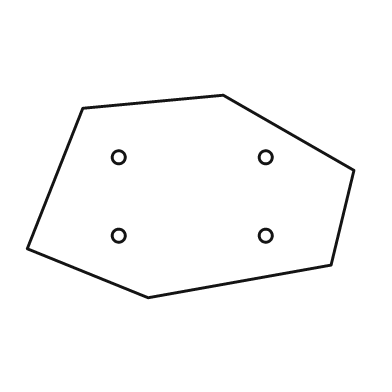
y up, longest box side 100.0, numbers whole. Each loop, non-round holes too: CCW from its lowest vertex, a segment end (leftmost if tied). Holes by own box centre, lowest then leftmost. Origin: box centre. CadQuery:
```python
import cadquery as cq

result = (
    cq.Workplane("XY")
    .moveTo(-13.0, -31.0)
    .lineTo(43.0, -21.0)
    .lineTo(50.0, 8.0)
    .lineTo(10.0, 31.0)
    .lineTo(-33.0, 27.0)
    .lineTo(-50.0, -16.0)
    .close()
    .moveTo(-22.0, -12.0)
    .circle(2.0)
    .moveTo(23.0, -12.0)
    .circle(2.0)
    .moveTo(-22.0, 12.0)
    .circle(2.0)
    .moveTo(23.0, 12.0)
    .circle(2.0)
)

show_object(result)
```